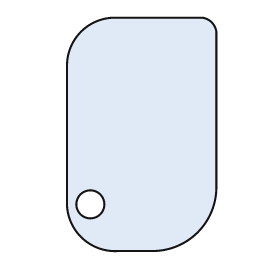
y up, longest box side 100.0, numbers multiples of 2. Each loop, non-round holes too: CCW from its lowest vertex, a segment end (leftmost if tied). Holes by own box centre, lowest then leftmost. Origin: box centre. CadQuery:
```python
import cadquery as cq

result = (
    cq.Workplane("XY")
    .moveTo(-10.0, -50.0)
    .lineTo(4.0, -50.0)
    .threePointArc((24.0, -42.0), (32.0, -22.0))
    .lineTo(32.0, 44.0)
    .threePointArc((30.0, 48.0), (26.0, 50.0))
    .lineTo(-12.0, 50.0)
    .threePointArc((-26.0, 44.0), (-32.0, 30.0))
    .lineTo(-32.0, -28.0)
    .threePointArc((-26.0, -44.0), (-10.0, -50.0))
    .close()
    .moveTo(-22.0, -30.0)
    .circle(6.0)
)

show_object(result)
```